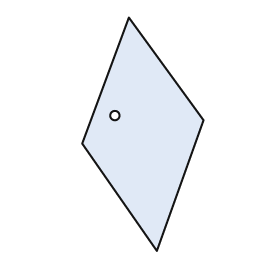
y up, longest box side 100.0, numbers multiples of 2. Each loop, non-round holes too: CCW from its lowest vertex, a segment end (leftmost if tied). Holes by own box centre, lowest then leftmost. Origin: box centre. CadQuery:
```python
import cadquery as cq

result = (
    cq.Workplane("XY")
    .moveTo(6.0, -50.0)
    .lineTo(26.0, 6.0)
    .lineTo(-6.0, 50.0)
    .lineTo(-26.0, -4.0)
    .close()
    .moveTo(-12.0, 8.0)
    .circle(2.0)
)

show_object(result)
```